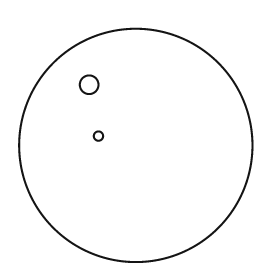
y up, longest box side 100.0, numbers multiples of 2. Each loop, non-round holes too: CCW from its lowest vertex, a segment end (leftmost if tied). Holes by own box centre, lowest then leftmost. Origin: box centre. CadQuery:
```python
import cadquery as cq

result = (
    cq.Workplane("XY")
    .moveTo(0.0, 0.0)
    .circle(50.0)
    .moveTo(-16.0, 4.0)
    .circle(2.0)
    .moveTo(-20.0, 26.0)
    .circle(4.0)
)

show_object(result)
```